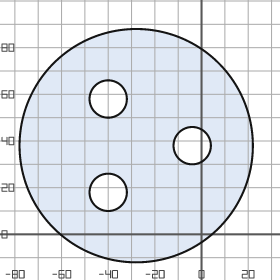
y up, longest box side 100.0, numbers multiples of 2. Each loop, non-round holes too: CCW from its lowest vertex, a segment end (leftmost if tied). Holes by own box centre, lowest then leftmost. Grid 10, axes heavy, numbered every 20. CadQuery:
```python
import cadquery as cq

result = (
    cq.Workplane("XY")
    .moveTo(-28.0, 38.0)
    .circle(50.0)
    .moveTo(-40.0, 18.0)
    .circle(8.0)
    .moveTo(-4.0, 38.0)
    .circle(8.0)
    .moveTo(-40.0, 58.0)
    .circle(8.0)
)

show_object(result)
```